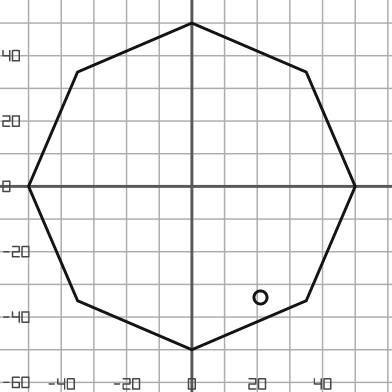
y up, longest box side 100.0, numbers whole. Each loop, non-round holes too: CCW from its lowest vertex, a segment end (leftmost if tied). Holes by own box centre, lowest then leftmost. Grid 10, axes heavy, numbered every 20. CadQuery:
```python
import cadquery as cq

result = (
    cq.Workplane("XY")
    .moveTo(0.0, -50.0)
    .lineTo(35.0, -35.0)
    .lineTo(50.0, 0.0)
    .lineTo(35.0, 35.0)
    .lineTo(0.0, 50.0)
    .lineTo(-35.0, 35.0)
    .lineTo(-50.0, 0.0)
    .lineTo(-35.0, -35.0)
    .close()
    .moveTo(21.0, -34.0)
    .circle(2.0)
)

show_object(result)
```